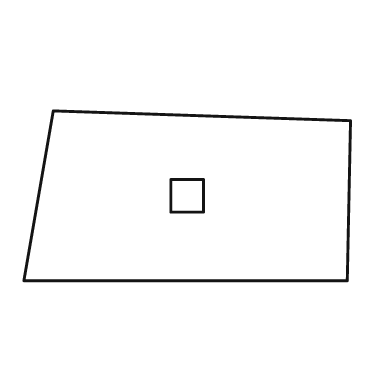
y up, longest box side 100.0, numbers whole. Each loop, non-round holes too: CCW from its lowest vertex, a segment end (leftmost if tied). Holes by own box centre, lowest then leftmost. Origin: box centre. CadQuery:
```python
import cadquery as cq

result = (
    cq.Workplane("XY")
    .moveTo(-50.0, -26.0)
    .lineTo(49.0, -26.0)
    .lineTo(50.0, 23.0)
    .lineTo(-41.0, 26.0)
    .close()
    .moveTo(-5.0, -5.0)
    .lineTo(5.0, -5.0)
    .lineTo(5.0, 5.0)
    .lineTo(-5.0, 5.0)
    .close()
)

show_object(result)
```